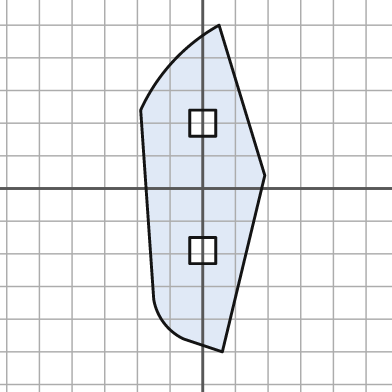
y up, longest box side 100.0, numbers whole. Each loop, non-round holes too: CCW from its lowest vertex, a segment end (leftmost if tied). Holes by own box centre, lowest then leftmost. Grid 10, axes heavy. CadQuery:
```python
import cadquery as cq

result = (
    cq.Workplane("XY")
    .moveTo(6.0, -50.0)
    .lineTo(19.0, 4.0)
    .lineTo(5.0, 50.0)
    .threePointArc((-9.0, 39.0), (-19.0, 24.0))
    .lineTo(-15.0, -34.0)
    .threePointArc((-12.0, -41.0), (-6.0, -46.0))
    .close()
    .moveTo(-4.0, -23.0)
    .lineTo(4.0, -23.0)
    .lineTo(4.0, -15.0)
    .lineTo(-4.0, -15.0)
    .close()
    .moveTo(-4.0, 16.0)
    .lineTo(4.0, 16.0)
    .lineTo(4.0, 24.0)
    .lineTo(-4.0, 24.0)
    .close()
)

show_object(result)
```